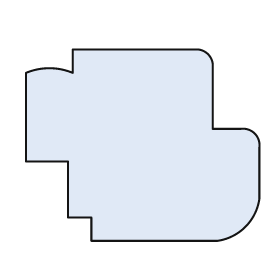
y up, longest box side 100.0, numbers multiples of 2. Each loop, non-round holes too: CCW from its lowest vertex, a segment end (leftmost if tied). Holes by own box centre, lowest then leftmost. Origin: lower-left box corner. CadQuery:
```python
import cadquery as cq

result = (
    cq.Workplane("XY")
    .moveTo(28.0, 0.0)
    .lineTo(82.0, 0.0)
    .threePointArc((94.0, 6.0), (100.0, 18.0))
    .lineTo(100.0, 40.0)
    .threePointArc((98.0, 46.0), (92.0, 48.0))
    .lineTo(80.0, 48.0)
    .lineTo(80.0, 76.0)
    .threePointArc((78.0, 80.0), (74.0, 82.0))
    .lineTo(20.0, 82.0)
    .lineTo(20.0, 72.0)
    .threePointArc((10.0, 74.0), (0.0, 72.0))
    .lineTo(0.0, 34.0)
    .lineTo(18.0, 34.0)
    .lineTo(18.0, 10.0)
    .lineTo(28.0, 10.0)
    .close()
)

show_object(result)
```